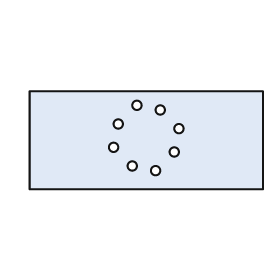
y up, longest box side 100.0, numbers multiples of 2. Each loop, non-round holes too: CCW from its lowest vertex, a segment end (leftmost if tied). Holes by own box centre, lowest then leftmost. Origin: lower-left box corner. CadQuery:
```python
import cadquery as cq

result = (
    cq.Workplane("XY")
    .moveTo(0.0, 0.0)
    .lineTo(100.0, 0.0)
    .lineTo(100.0, 42.0)
    .lineTo(0.0, 42.0)
    .close()
    .moveTo(54.0, 8.0)
    .circle(2.0)
    .moveTo(44.0, 10.0)
    .circle(2.0)
    .moveTo(62.0, 16.0)
    .circle(2.0)
    .moveTo(36.0, 18.0)
    .circle(2.0)
    .moveTo(64.0, 26.0)
    .circle(2.0)
    .moveTo(38.0, 28.0)
    .circle(2.0)
    .moveTo(56.0, 34.0)
    .circle(2.0)
    .moveTo(46.0, 36.0)
    .circle(2.0)
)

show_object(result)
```